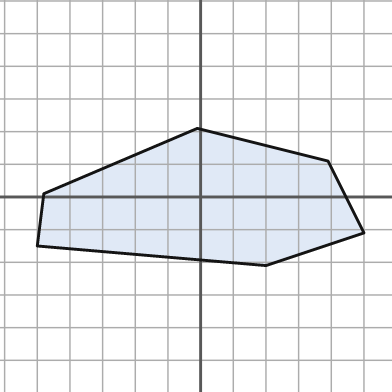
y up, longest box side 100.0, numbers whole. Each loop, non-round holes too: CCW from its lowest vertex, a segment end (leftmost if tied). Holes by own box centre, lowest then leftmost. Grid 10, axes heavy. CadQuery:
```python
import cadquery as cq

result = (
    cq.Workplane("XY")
    .moveTo(20.0, -21.0)
    .lineTo(50.0, -11.0)
    .lineTo(39.0, 11.0)
    .lineTo(-1.0, 21.0)
    .lineTo(-48.0, 1.0)
    .lineTo(-50.0, -15.0)
    .close()
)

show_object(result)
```